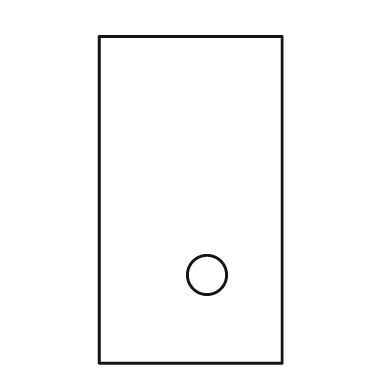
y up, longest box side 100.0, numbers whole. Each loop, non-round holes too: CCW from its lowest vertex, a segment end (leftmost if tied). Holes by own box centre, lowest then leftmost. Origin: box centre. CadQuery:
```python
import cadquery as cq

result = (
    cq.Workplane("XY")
    .moveTo(-28.0, -50.0)
    .lineTo(28.0, -50.0)
    .lineTo(28.0, 50.0)
    .lineTo(-28.0, 50.0)
    .close()
    .moveTo(5.0, -23.0)
    .circle(6.0)
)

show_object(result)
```